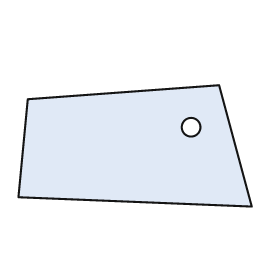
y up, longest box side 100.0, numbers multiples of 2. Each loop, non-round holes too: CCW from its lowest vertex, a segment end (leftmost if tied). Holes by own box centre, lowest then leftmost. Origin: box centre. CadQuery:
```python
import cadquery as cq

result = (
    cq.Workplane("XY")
    .moveTo(50.0, -26.0)
    .lineTo(36.0, 26.0)
    .lineTo(-46.0, 20.0)
    .lineTo(-50.0, -22.0)
    .close()
    .moveTo(24.0, 8.0)
    .circle(4.0)
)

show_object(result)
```